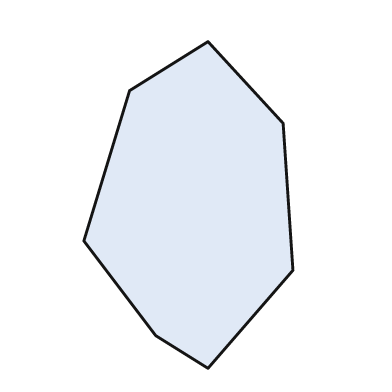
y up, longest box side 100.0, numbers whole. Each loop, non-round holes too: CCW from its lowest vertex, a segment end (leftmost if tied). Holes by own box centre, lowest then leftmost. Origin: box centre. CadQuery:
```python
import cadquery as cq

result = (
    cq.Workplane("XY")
    .moveTo(6.0, -50.0)
    .lineTo(32.0, -20.0)
    .lineTo(29.0, 25.0)
    .lineTo(6.0, 50.0)
    .lineTo(-18.0, 35.0)
    .lineTo(-32.0, -11.0)
    .lineTo(-10.0, -40.0)
    .close()
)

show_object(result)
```